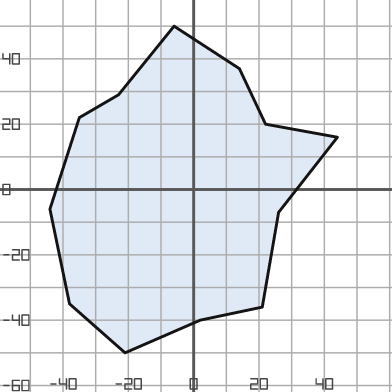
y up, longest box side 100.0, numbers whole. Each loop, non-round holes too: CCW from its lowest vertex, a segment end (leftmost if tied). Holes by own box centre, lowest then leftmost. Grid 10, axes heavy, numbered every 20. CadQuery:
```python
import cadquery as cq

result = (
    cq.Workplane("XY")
    .moveTo(-21.0, -50.0)
    .lineTo(2.0, -40.0)
    .lineTo(21.0, -36.0)
    .lineTo(26.0, -7.0)
    .lineTo(44.0, 16.0)
    .lineTo(22.0, 20.0)
    .lineTo(14.0, 37.0)
    .lineTo(-6.0, 50.0)
    .lineTo(-23.0, 29.0)
    .lineTo(-35.0, 22.0)
    .lineTo(-44.0, -6.0)
    .lineTo(-38.0, -35.0)
    .close()
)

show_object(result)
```